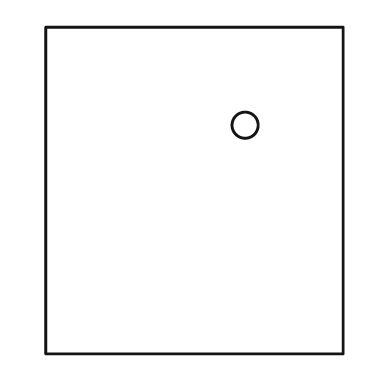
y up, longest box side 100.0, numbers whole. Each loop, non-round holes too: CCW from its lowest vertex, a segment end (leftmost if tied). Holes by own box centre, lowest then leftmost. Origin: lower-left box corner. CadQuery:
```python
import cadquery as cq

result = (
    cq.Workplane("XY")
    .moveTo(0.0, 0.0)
    .lineTo(91.0, 0.0)
    .lineTo(91.0, 100.0)
    .lineTo(0.0, 100.0)
    .close()
    .moveTo(61.0, 70.0)
    .circle(4.0)
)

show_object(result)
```